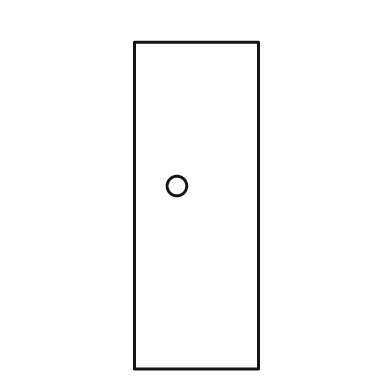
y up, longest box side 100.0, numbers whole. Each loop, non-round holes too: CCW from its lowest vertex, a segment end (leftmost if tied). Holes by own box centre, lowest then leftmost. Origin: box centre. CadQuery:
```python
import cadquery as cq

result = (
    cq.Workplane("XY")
    .moveTo(-19.0, -50.0)
    .lineTo(19.0, -50.0)
    .lineTo(19.0, 50.0)
    .lineTo(-19.0, 50.0)
    .close()
    .moveTo(-6.0, 6.0)
    .circle(3.0)
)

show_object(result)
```